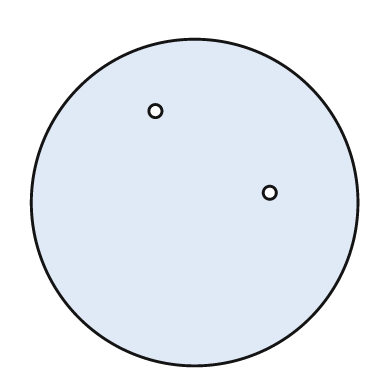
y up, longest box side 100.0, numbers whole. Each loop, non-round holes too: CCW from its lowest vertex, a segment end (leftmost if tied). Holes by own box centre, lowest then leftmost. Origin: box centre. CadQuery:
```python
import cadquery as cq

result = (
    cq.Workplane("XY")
    .moveTo(0.0, 0.0)
    .circle(50.0)
    .moveTo(23.0, 3.0)
    .circle(2.0)
    .moveTo(-12.0, 28.0)
    .circle(2.0)
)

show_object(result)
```